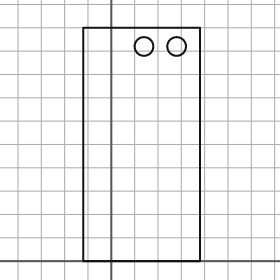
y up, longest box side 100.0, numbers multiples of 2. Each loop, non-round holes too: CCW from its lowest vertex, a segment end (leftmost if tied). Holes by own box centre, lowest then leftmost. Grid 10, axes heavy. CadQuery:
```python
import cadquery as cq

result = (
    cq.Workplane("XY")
    .moveTo(-12.0, 0.0)
    .lineTo(38.0, 0.0)
    .lineTo(38.0, 100.0)
    .lineTo(-12.0, 100.0)
    .close()
    .moveTo(14.0, 92.0)
    .circle(4.0)
    .moveTo(28.0, 92.0)
    .circle(4.0)
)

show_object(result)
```